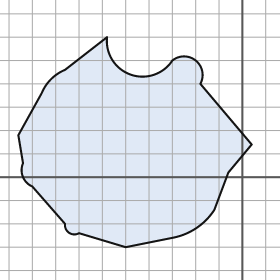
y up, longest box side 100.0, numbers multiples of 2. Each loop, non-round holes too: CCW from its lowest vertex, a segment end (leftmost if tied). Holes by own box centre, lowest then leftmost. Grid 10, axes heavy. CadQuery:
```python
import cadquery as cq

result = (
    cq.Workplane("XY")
    .moveTo(-50.0, -30.0)
    .lineTo(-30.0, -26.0)
    .threePointArc((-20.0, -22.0), (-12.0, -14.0))
    .lineTo(-6.0, 2.0)
    .lineTo(4.0, 14.0)
    .lineTo(-18.0, 40.0)
    .threePointArc((-20.0, 50.0), (-30.0, 50.0))
    .threePointArc((-48.0, 44.0), (-58.0, 60.0))
    .lineTo(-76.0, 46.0)
    .threePointArc((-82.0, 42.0), (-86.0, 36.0))
    .lineTo(-96.0, 18.0)
    .lineTo(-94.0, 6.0)
    .threePointArc((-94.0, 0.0), (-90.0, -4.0))
    .lineTo(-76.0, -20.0)
    .threePointArc((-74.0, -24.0), (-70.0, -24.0))
    .close()
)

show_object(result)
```